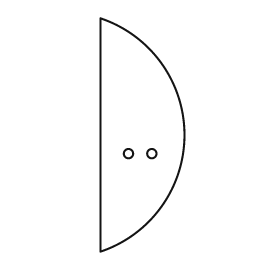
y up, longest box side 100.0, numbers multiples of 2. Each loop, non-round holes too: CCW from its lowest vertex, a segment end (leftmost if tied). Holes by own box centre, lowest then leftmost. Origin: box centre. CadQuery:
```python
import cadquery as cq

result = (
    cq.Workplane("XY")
    .moveTo(-18.0, -50.0)
    .threePointArc((18.0, 0.0), (-18.0, 50.0))
    .close()
    .moveTo(-6.0, -8.0)
    .circle(2.0)
    .moveTo(4.0, -8.0)
    .circle(2.0)
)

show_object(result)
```